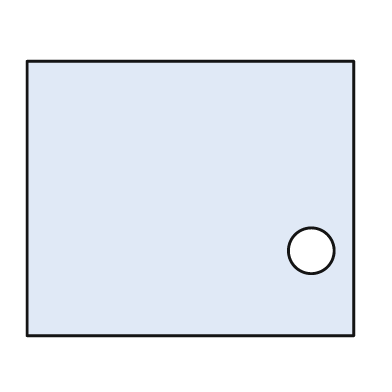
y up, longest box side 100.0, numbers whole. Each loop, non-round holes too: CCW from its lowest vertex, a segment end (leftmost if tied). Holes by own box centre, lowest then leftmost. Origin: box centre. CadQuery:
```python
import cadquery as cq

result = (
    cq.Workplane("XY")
    .moveTo(-50.0, -42.0)
    .lineTo(50.0, -42.0)
    .lineTo(50.0, 42.0)
    .lineTo(-50.0, 42.0)
    .close()
    .moveTo(37.0, -16.0)
    .circle(7.0)
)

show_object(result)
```